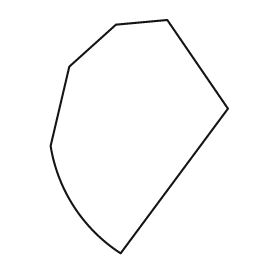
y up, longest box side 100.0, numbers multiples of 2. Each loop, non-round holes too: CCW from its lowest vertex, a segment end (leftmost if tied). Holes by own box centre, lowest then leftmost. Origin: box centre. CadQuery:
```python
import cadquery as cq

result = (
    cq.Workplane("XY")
    .moveTo(-8.0, -50.0)
    .lineTo(38.0, 12.0)
    .lineTo(12.0, 50.0)
    .lineTo(-10.0, 48.0)
    .lineTo(-30.0, 30.0)
    .lineTo(-38.0, -4.0)
    .threePointArc((-28.0, -30.0), (-8.0, -50.0))
    .close()
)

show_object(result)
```